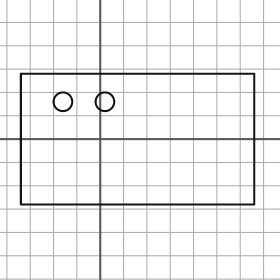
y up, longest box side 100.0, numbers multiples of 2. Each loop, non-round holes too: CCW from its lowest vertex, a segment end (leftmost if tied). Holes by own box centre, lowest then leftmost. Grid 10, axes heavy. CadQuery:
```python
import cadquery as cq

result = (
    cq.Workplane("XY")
    .moveTo(-34.0, -28.0)
    .lineTo(66.0, -28.0)
    .lineTo(66.0, 28.0)
    .lineTo(-34.0, 28.0)
    .close()
    .moveTo(-16.0, 16.0)
    .circle(4.0)
    .moveTo(2.0, 16.0)
    .circle(4.0)
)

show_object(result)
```